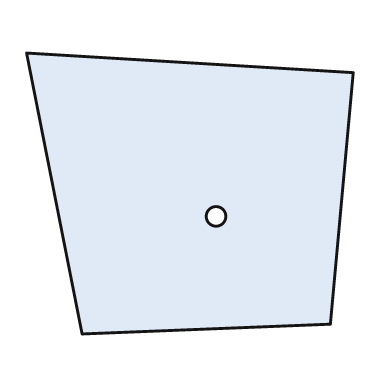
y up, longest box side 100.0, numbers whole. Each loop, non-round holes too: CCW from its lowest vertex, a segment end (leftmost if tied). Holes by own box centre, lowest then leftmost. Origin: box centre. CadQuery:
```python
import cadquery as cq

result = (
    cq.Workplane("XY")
    .moveTo(-33.0, -43.0)
    .lineTo(43.0, -40.0)
    .lineTo(50.0, 37.0)
    .lineTo(-50.0, 43.0)
    .close()
    .moveTo(8.0, -7.0)
    .circle(3.0)
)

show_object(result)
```